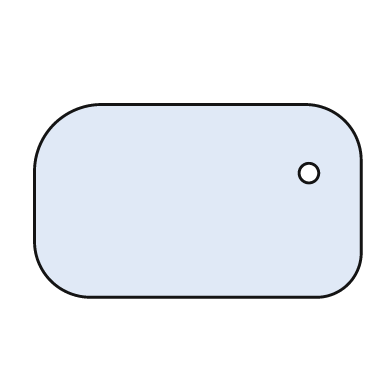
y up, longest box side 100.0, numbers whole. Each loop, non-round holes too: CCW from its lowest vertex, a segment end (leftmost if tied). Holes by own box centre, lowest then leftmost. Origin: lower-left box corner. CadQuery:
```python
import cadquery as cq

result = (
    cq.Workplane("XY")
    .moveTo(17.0, 0.0)
    .lineTo(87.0, 0.0)
    .threePointArc((96.0, 4.0), (100.0, 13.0))
    .lineTo(100.0, 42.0)
    .threePointArc((95.0, 54.0), (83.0, 59.0))
    .lineTo(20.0, 59.0)
    .threePointArc((6.0, 53.0), (0.0, 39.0))
    .lineTo(0.0, 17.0)
    .threePointArc((5.0, 5.0), (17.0, 0.0))
    .close()
    .moveTo(84.0, 38.0)
    .circle(3.0)
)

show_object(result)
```